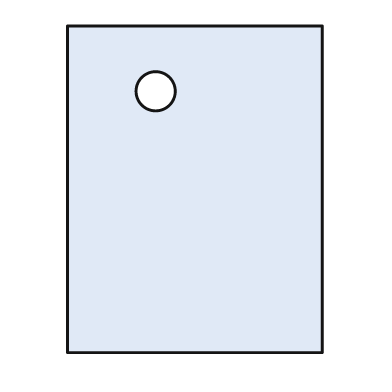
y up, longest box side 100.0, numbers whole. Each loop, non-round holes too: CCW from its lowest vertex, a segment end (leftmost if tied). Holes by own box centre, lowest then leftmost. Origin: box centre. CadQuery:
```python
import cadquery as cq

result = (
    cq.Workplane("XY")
    .moveTo(-39.0, -50.0)
    .lineTo(39.0, -50.0)
    .lineTo(39.0, 50.0)
    .lineTo(-39.0, 50.0)
    .close()
    .moveTo(-12.0, 30.0)
    .circle(6.0)
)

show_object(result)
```